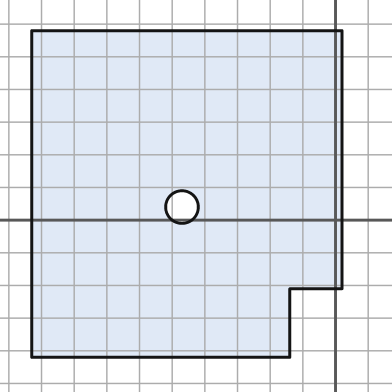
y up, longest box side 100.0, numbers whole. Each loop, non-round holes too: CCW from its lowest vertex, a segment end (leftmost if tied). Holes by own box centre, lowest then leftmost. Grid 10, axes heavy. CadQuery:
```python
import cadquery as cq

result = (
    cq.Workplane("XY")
    .moveTo(-93.0, -42.0)
    .lineTo(-14.0, -42.0)
    .lineTo(-14.0, -21.0)
    .lineTo(2.0, -21.0)
    .lineTo(2.0, 58.0)
    .lineTo(-93.0, 58.0)
    .close()
    .moveTo(-47.0, 4.0)
    .circle(5.0)
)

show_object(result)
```